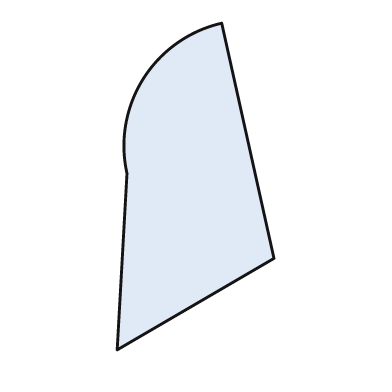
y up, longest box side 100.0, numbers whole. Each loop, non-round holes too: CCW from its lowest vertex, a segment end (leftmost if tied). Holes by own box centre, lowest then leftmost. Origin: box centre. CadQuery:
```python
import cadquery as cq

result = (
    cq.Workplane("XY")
    .moveTo(-24.0, -50.0)
    .lineTo(24.0, -22.0)
    .lineTo(8.0, 50.0)
    .threePointArc((-16.0, 33.0), (-21.0, 4.0))
    .close()
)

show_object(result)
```